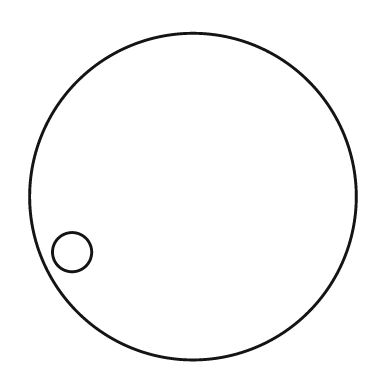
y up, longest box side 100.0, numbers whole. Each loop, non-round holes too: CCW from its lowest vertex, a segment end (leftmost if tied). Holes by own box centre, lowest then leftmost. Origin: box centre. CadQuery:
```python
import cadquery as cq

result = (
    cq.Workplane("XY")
    .moveTo(0.0, 0.0)
    .circle(50.0)
    .moveTo(-37.0, -17.0)
    .circle(6.0)
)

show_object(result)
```